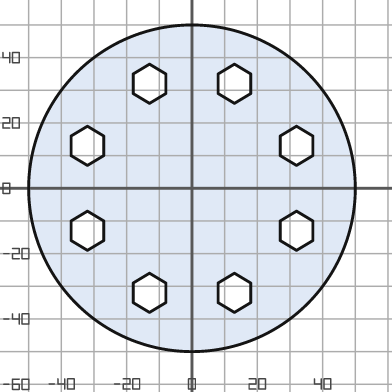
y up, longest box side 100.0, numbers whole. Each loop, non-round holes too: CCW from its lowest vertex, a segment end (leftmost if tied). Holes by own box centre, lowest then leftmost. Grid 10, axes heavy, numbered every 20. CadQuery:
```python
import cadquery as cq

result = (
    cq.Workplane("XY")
    .moveTo(0.0, 0.0)
    .circle(50.0)
    .moveTo(-13.0, -38.0)
    .lineTo(-8.0, -35.0)
    .lineTo(-8.0, -29.0)
    .lineTo(-13.0, -26.0)
    .lineTo(-18.0, -29.0)
    .lineTo(-18.0, -35.0)
    .close()
    .moveTo(13.0, -38.0)
    .lineTo(18.0, -35.0)
    .lineTo(18.0, -29.0)
    .lineTo(13.0, -26.0)
    .lineTo(8.0, -29.0)
    .lineTo(8.0, -35.0)
    .close()
    .moveTo(-32.0, -19.0)
    .lineTo(-27.0, -16.0)
    .lineTo(-27.0, -10.0)
    .lineTo(-32.0, -7.0)
    .lineTo(-37.0, -10.0)
    .lineTo(-37.0, -16.0)
    .close()
    .moveTo(32.0, -19.0)
    .lineTo(37.0, -16.0)
    .lineTo(37.0, -10.0)
    .lineTo(32.0, -7.0)
    .lineTo(27.0, -10.0)
    .lineTo(27.0, -16.0)
    .close()
    .moveTo(-32.0, 7.0)
    .lineTo(-27.0, 10.0)
    .lineTo(-27.0, 16.0)
    .lineTo(-32.0, 19.0)
    .lineTo(-37.0, 16.0)
    .lineTo(-37.0, 10.0)
    .close()
    .moveTo(32.0, 7.0)
    .lineTo(37.0, 10.0)
    .lineTo(37.0, 16.0)
    .lineTo(32.0, 19.0)
    .lineTo(27.0, 16.0)
    .lineTo(27.0, 10.0)
    .close()
    .moveTo(-13.0, 26.0)
    .lineTo(-8.0, 29.0)
    .lineTo(-8.0, 35.0)
    .lineTo(-13.0, 38.0)
    .lineTo(-18.0, 35.0)
    .lineTo(-18.0, 29.0)
    .close()
    .moveTo(13.0, 26.0)
    .lineTo(18.0, 29.0)
    .lineTo(18.0, 35.0)
    .lineTo(13.0, 38.0)
    .lineTo(8.0, 35.0)
    .lineTo(8.0, 29.0)
    .close()
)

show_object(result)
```